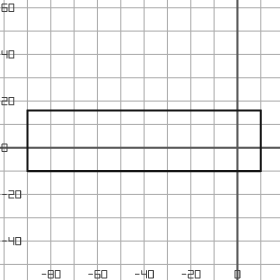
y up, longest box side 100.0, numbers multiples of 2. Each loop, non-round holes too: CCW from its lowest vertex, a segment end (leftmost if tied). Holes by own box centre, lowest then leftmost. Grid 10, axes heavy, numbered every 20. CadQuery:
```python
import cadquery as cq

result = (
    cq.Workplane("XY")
    .moveTo(-90.0, -10.0)
    .lineTo(10.0, -10.0)
    .lineTo(10.0, 16.0)
    .lineTo(-90.0, 16.0)
    .close()
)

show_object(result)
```